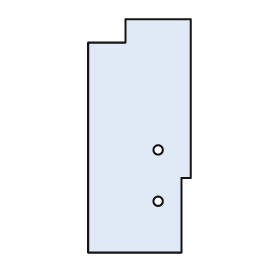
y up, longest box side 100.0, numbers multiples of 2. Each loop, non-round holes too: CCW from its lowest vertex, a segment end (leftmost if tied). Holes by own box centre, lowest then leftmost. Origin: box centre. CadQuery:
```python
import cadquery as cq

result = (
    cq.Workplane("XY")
    .moveTo(-22.0, -50.0)
    .lineTo(18.0, -50.0)
    .lineTo(18.0, -18.0)
    .lineTo(22.0, -18.0)
    .lineTo(22.0, 50.0)
    .lineTo(-6.0, 50.0)
    .lineTo(-6.0, 40.0)
    .lineTo(-22.0, 40.0)
    .close()
    .moveTo(8.0, -28.0)
    .circle(2.0)
    .moveTo(8.0, -6.0)
    .circle(2.0)
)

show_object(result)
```